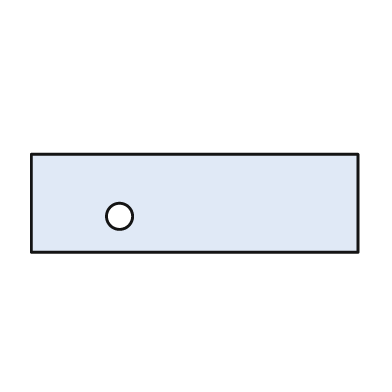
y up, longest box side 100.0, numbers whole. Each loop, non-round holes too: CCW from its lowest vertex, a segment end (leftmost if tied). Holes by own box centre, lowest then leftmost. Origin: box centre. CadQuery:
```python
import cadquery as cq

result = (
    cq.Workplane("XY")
    .moveTo(-50.0, -15.0)
    .lineTo(50.0, -15.0)
    .lineTo(50.0, 15.0)
    .lineTo(-50.0, 15.0)
    .close()
    .moveTo(-23.0, -4.0)
    .circle(4.0)
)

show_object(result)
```